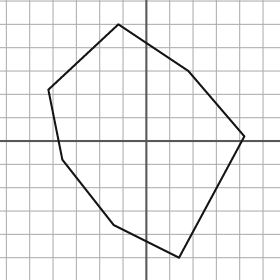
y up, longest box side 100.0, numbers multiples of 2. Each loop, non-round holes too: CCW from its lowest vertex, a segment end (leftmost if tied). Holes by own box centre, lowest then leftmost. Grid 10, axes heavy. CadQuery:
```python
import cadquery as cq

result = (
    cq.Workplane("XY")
    .moveTo(14.0, -50.0)
    .lineTo(42.0, 2.0)
    .lineTo(18.0, 30.0)
    .lineTo(-12.0, 50.0)
    .lineTo(-42.0, 22.0)
    .lineTo(-36.0, -8.0)
    .lineTo(-14.0, -36.0)
    .close()
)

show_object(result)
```